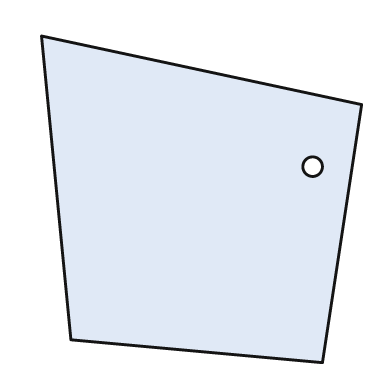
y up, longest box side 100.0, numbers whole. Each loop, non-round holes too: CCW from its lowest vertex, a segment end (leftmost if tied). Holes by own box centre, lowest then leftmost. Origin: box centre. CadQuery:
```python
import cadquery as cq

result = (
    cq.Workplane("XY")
    .moveTo(37.0, -50.0)
    .lineTo(49.0, 29.0)
    .lineTo(-49.0, 50.0)
    .lineTo(-40.0, -43.0)
    .close()
    .moveTo(34.0, 10.0)
    .circle(3.0)
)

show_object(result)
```